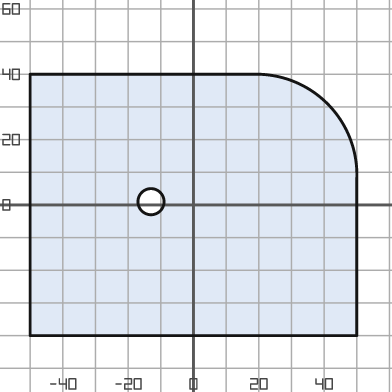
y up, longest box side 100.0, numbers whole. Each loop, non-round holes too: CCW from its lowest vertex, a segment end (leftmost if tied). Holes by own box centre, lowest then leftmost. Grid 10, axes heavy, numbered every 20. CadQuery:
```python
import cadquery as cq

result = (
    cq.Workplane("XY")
    .moveTo(-50.0, -40.0)
    .lineTo(50.0, -40.0)
    .lineTo(50.0, 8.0)
    .threePointArc((41.0, 31.0), (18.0, 40.0))
    .lineTo(-50.0, 40.0)
    .close()
    .moveTo(-13.0, 1.0)
    .circle(4.0)
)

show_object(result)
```